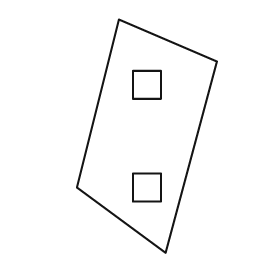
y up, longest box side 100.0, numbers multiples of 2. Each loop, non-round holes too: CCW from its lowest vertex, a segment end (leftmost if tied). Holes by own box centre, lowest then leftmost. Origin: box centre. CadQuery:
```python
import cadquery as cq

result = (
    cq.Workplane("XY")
    .moveTo(8.0, -50.0)
    .lineTo(30.0, 32.0)
    .lineTo(-12.0, 50.0)
    .lineTo(-30.0, -22.0)
    .close()
    .moveTo(-6.0, -28.0)
    .lineTo(6.0, -28.0)
    .lineTo(6.0, -16.0)
    .lineTo(-6.0, -16.0)
    .close()
    .moveTo(-6.0, 16.0)
    .lineTo(6.0, 16.0)
    .lineTo(6.0, 28.0)
    .lineTo(-6.0, 28.0)
    .close()
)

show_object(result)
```